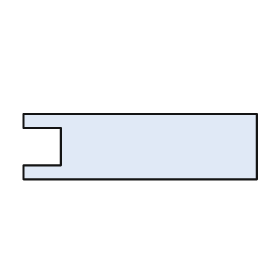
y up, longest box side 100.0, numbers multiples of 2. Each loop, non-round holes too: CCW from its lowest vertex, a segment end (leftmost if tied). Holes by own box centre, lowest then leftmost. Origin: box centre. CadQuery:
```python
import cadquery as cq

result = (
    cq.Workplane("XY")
    .moveTo(-50.0, -14.0)
    .lineTo(50.0, -14.0)
    .lineTo(50.0, 14.0)
    .lineTo(-50.0, 14.0)
    .lineTo(-50.0, 8.0)
    .lineTo(-34.0, 8.0)
    .lineTo(-34.0, -8.0)
    .lineTo(-50.0, -8.0)
    .close()
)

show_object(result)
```